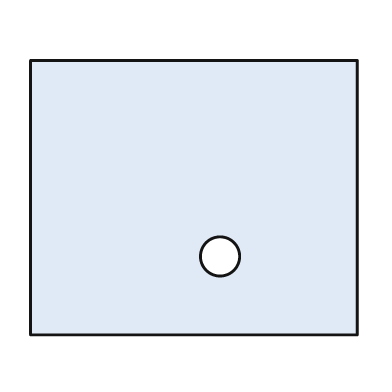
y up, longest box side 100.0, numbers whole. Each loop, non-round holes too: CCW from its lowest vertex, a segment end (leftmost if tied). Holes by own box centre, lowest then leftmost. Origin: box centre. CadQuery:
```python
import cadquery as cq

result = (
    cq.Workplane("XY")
    .moveTo(-50.0, -42.0)
    .lineTo(50.0, -42.0)
    .lineTo(50.0, 42.0)
    .lineTo(-50.0, 42.0)
    .close()
    .moveTo(8.0, -18.0)
    .circle(6.0)
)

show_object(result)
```